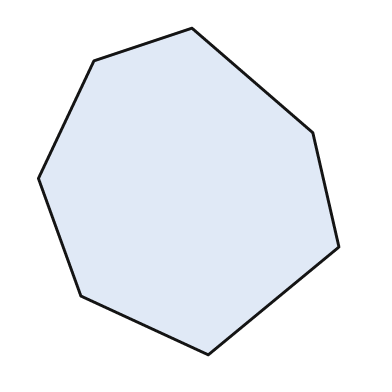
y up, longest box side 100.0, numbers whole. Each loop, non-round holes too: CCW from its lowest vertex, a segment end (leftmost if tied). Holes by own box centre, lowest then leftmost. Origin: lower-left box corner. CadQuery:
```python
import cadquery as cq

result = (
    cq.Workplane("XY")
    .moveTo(52.0, 0.0)
    .lineTo(92.0, 33.0)
    .lineTo(84.0, 68.0)
    .lineTo(47.0, 100.0)
    .lineTo(17.0, 90.0)
    .lineTo(0.0, 54.0)
    .lineTo(13.0, 18.0)
    .close()
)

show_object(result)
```